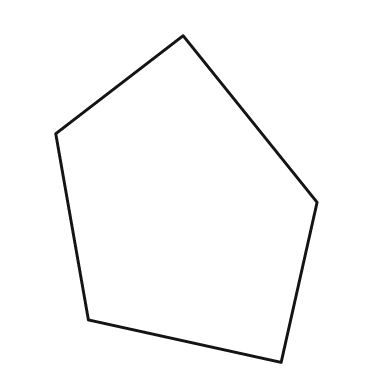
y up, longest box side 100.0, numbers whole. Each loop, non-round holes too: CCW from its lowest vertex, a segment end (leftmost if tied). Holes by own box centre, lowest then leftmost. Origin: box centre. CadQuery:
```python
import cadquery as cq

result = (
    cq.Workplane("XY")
    .moveTo(29.0, -50.0)
    .lineTo(40.0, -1.0)
    .lineTo(-1.0, 50.0)
    .lineTo(-40.0, 20.0)
    .lineTo(-30.0, -37.0)
    .close()
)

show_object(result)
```